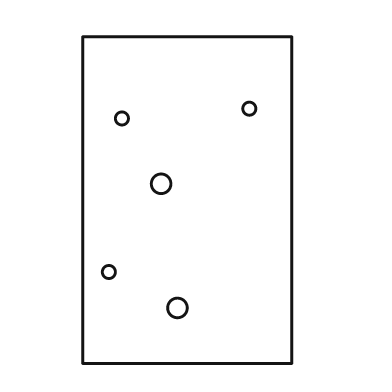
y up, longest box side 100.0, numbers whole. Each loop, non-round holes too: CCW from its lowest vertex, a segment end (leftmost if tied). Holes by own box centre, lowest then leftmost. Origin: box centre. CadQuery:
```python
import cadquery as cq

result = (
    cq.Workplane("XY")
    .moveTo(-32.0, -50.0)
    .lineTo(32.0, -50.0)
    .lineTo(32.0, 50.0)
    .lineTo(-32.0, 50.0)
    .close()
    .moveTo(-3.0, -33.0)
    .circle(3.0)
    .moveTo(-24.0, -22.0)
    .circle(2.0)
    .moveTo(-8.0, 5.0)
    .circle(3.0)
    .moveTo(-20.0, 25.0)
    .circle(2.0)
    .moveTo(19.0, 28.0)
    .circle(2.0)
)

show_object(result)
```